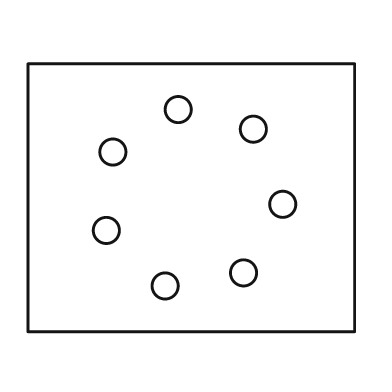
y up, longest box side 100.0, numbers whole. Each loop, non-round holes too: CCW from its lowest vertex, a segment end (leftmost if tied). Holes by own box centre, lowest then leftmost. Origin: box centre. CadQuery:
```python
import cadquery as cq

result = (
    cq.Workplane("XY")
    .moveTo(-50.0, -41.0)
    .lineTo(50.0, -41.0)
    .lineTo(50.0, 41.0)
    .lineTo(-50.0, 41.0)
    .close()
    .moveTo(-8.0, -27.0)
    .circle(4.0)
    .moveTo(16.0, -23.0)
    .circle(4.0)
    .moveTo(-26.0, -10.0)
    .circle(4.0)
    .moveTo(28.0, -2.0)
    .circle(4.0)
    .moveTo(-24.0, 14.0)
    .circle(4.0)
    .moveTo(19.0, 21.0)
    .circle(4.0)
    .moveTo(-4.0, 27.0)
    .circle(4.0)
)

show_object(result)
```